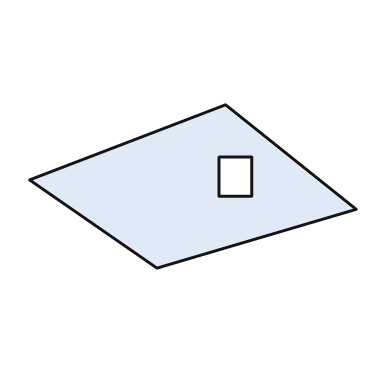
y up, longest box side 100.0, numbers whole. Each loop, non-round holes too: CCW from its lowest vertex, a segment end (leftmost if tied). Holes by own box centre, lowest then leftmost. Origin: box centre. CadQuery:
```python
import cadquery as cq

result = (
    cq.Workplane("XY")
    .moveTo(-11.0, -25.0)
    .lineTo(50.0, -7.0)
    .lineTo(10.0, 25.0)
    .lineTo(-50.0, 2.0)
    .close()
    .moveTo(8.0, -3.0)
    .lineTo(18.0, -3.0)
    .lineTo(18.0, 9.0)
    .lineTo(8.0, 9.0)
    .close()
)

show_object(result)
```